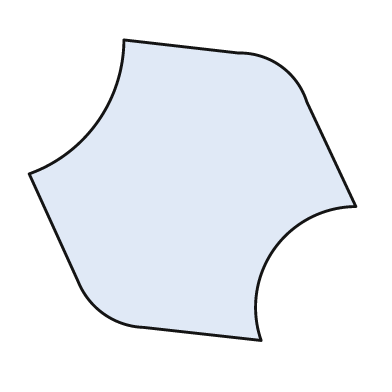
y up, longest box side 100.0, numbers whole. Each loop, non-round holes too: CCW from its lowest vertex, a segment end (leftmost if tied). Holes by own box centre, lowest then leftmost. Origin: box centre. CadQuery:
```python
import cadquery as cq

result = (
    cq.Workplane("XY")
    .moveTo(21.0, -46.0)
    .threePointArc((25.0, -18.0), (50.0, -5.0))
    .lineTo(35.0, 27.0)
    .threePointArc((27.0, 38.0), (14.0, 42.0))
    .lineTo(-21.0, 46.0)
    .threePointArc((-29.0, 21.0), (-50.0, 5.0))
    .lineTo(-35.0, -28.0)
    .threePointArc((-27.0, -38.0), (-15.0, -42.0))
    .close()
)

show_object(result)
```